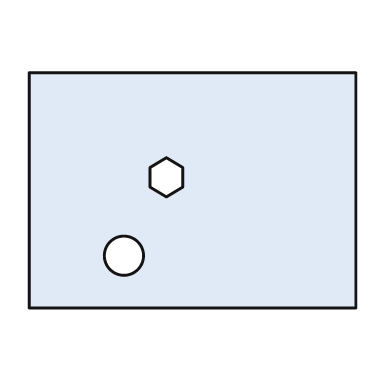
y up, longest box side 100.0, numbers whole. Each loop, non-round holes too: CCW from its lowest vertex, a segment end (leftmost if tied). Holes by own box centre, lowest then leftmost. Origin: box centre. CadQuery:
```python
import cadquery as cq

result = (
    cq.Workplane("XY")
    .moveTo(-50.0, -36.0)
    .lineTo(50.0, -36.0)
    .lineTo(50.0, 36.0)
    .lineTo(-50.0, 36.0)
    .close()
    .moveTo(-21.0, -20.0)
    .circle(6.0)
    .moveTo(-8.0, -2.0)
    .lineTo(-3.0, 1.0)
    .lineTo(-3.0, 7.0)
    .lineTo(-8.0, 10.0)
    .lineTo(-13.0, 7.0)
    .lineTo(-13.0, 1.0)
    .close()
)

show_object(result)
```